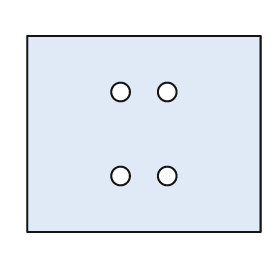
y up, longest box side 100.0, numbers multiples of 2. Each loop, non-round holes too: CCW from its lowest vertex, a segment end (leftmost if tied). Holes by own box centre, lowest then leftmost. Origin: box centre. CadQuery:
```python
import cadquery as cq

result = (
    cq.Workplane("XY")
    .moveTo(-50.0, -42.0)
    .lineTo(50.0, -42.0)
    .lineTo(50.0, 42.0)
    .lineTo(-50.0, 42.0)
    .close()
    .moveTo(-10.0, -18.0)
    .circle(4.0)
    .moveTo(10.0, -18.0)
    .circle(4.0)
    .moveTo(-10.0, 18.0)
    .circle(4.0)
    .moveTo(10.0, 18.0)
    .circle(4.0)
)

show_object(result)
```